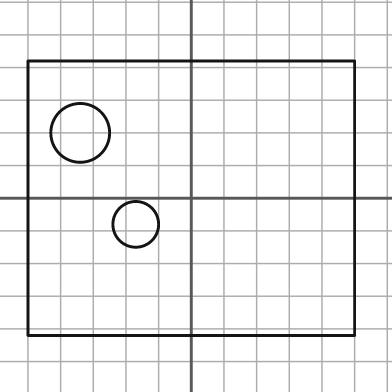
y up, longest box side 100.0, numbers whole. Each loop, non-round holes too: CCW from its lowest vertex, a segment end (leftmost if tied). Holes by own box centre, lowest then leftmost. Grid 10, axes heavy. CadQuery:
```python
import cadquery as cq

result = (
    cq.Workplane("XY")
    .moveTo(-50.0, -42.0)
    .lineTo(50.0, -42.0)
    .lineTo(50.0, 42.0)
    .lineTo(-50.0, 42.0)
    .close()
    .moveTo(-17.0, -8.0)
    .circle(7.0)
    .moveTo(-34.0, 20.0)
    .circle(9.0)
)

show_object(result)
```